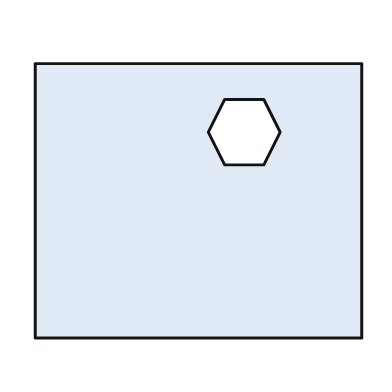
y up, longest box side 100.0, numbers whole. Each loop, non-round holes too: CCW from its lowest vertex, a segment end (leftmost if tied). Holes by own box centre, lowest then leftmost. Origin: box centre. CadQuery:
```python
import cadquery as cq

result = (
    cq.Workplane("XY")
    .moveTo(-50.0, -42.0)
    .lineTo(50.0, -42.0)
    .lineTo(50.0, 42.0)
    .lineTo(-50.0, 42.0)
    .close()
    .moveTo(8.0, 11.0)
    .lineTo(20.0, 11.0)
    .lineTo(25.0, 21.0)
    .lineTo(20.0, 31.0)
    .lineTo(8.0, 31.0)
    .lineTo(3.0, 21.0)
    .close()
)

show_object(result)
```